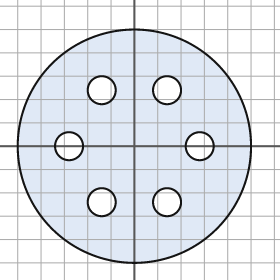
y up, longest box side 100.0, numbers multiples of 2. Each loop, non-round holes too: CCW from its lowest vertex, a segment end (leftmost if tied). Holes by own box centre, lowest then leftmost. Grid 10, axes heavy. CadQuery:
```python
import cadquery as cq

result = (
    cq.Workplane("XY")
    .moveTo(0.0, 0.0)
    .circle(50.0)
    .moveTo(-14.0, -24.0)
    .circle(6.0)
    .moveTo(14.0, -24.0)
    .circle(6.0)
    .moveTo(-28.0, 0.0)
    .circle(6.0)
    .moveTo(28.0, 0.0)
    .circle(6.0)
    .moveTo(-14.0, 24.0)
    .circle(6.0)
    .moveTo(14.0, 24.0)
    .circle(6.0)
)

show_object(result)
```